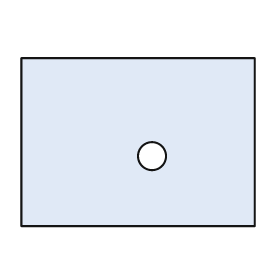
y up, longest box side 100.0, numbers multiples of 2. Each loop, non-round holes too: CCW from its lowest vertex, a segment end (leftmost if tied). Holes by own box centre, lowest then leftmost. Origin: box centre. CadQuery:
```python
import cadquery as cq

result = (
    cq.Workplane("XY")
    .moveTo(-50.0, -36.0)
    .lineTo(50.0, -36.0)
    .lineTo(50.0, 36.0)
    .lineTo(-50.0, 36.0)
    .close()
    .moveTo(6.0, -6.0)
    .circle(6.0)
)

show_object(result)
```